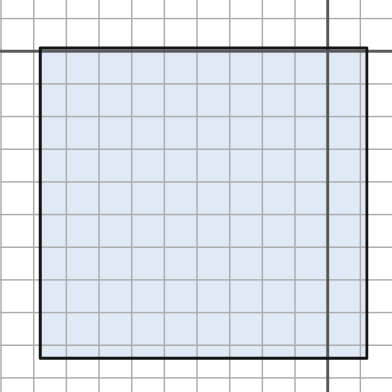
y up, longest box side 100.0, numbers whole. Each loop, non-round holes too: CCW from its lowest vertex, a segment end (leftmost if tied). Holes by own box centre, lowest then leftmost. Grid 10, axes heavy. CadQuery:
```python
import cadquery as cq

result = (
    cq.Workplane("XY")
    .moveTo(-88.0, -94.0)
    .lineTo(12.0, -94.0)
    .lineTo(12.0, 1.0)
    .lineTo(-88.0, 1.0)
    .close()
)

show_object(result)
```